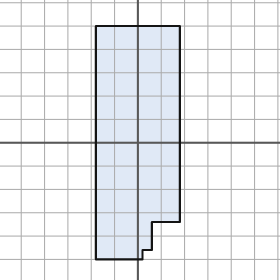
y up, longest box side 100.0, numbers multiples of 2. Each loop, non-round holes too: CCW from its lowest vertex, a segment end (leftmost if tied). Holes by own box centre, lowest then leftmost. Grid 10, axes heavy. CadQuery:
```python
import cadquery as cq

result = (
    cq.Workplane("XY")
    .moveTo(-18.0, -50.0)
    .lineTo(2.0, -50.0)
    .lineTo(2.0, -46.0)
    .lineTo(6.0, -46.0)
    .lineTo(6.0, -34.0)
    .lineTo(18.0, -34.0)
    .lineTo(18.0, 50.0)
    .lineTo(-18.0, 50.0)
    .close()
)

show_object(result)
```